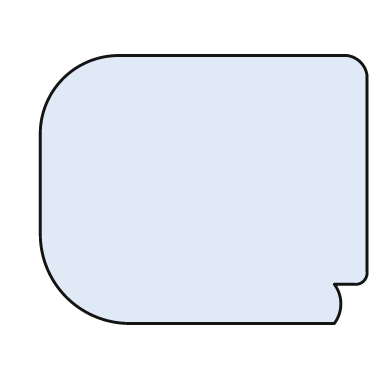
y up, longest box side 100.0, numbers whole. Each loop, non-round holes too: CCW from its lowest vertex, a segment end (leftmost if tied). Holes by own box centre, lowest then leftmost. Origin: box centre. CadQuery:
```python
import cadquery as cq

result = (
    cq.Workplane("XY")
    .moveTo(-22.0, -41.0)
    .lineTo(40.0, -41.0)
    .threePointArc((42.0, -35.0), (40.0, -29.0))
    .lineTo(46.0, -29.0)
    .threePointArc((49.0, -28.0), (50.0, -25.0))
    .lineTo(50.0, 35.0)
    .threePointArc((48.0, 39.0), (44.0, 41.0))
    .lineTo(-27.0, 41.0)
    .threePointArc((-43.0, 34.0), (-50.0, 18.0))
    .lineTo(-50.0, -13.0)
    .threePointArc((-42.0, -33.0), (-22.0, -41.0))
    .close()
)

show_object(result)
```